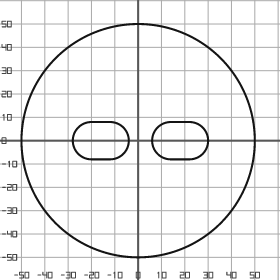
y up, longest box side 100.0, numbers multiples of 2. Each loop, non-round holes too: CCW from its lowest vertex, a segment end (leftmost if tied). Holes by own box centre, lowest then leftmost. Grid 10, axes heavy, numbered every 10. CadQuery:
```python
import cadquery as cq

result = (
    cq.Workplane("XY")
    .moveTo(0.0, 0.0)
    .circle(50.0)
    .moveTo(-20.0, -8.0)
    .lineTo(-12.0, -8.0)
    .threePointArc((-4.0, 0.0), (-12.0, 8.0))
    .lineTo(-20.0, 8.0)
    .threePointArc((-28.0, 0.0), (-20.0, -8.0))
    .close()
    .moveTo(14.0, -8.0)
    .lineTo(22.0, -8.0)
    .threePointArc((30.0, 0.0), (22.0, 8.0))
    .lineTo(14.0, 8.0)
    .threePointArc((6.0, 0.0), (14.0, -8.0))
    .close()
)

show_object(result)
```